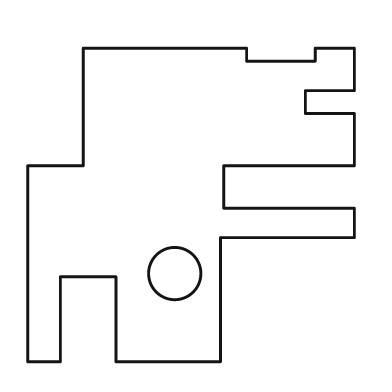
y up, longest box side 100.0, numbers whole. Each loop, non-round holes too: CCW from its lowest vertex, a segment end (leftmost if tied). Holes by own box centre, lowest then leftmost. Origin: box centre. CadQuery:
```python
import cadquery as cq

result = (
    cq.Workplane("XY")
    .moveTo(-50.0, -48.0)
    .lineTo(-40.0, -48.0)
    .lineTo(-40.0, -22.0)
    .lineTo(-23.0, -22.0)
    .lineTo(-23.0, -48.0)
    .lineTo(9.0, -48.0)
    .lineTo(9.0, -10.0)
    .lineTo(50.0, -10.0)
    .lineTo(50.0, -1.0)
    .lineTo(10.0, -1.0)
    .lineTo(10.0, 12.0)
    .lineTo(50.0, 12.0)
    .lineTo(50.0, 28.0)
    .lineTo(35.0, 28.0)
    .lineTo(35.0, 35.0)
    .lineTo(50.0, 35.0)
    .lineTo(50.0, 48.0)
    .lineTo(38.0, 48.0)
    .lineTo(38.0, 44.0)
    .lineTo(17.0, 44.0)
    .lineTo(17.0, 48.0)
    .lineTo(-33.0, 48.0)
    .lineTo(-33.0, 12.0)
    .lineTo(-50.0, 12.0)
    .close()
    .moveTo(-5.0, -21.0)
    .circle(8.0)
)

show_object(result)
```